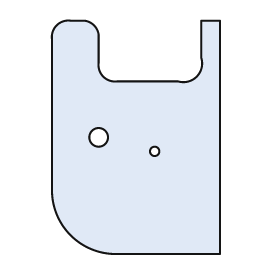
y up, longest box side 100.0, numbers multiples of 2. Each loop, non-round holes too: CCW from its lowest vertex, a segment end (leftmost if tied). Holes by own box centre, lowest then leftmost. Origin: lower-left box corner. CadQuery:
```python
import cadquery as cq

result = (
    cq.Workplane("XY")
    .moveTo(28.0, 0.0)
    .lineTo(72.0, 0.0)
    .lineTo(72.0, 100.0)
    .lineTo(64.0, 100.0)
    .lineTo(64.0, 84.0)
    .threePointArc((62.0, 76.0), (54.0, 74.0))
    .lineTo(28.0, 74.0)
    .threePointArc((22.0, 76.0), (20.0, 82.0))
    .lineTo(20.0, 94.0)
    .threePointArc((18.0, 98.0), (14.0, 100.0))
    .lineTo(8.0, 100.0)
    .threePointArc((2.0, 98.0), (0.0, 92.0))
    .lineTo(0.0, 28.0)
    .threePointArc((8.0, 8.0), (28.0, 0.0))
    .close()
    .moveTo(44.0, 44.0)
    .circle(2.0)
    .moveTo(20.0, 50.0)
    .circle(4.0)
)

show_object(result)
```